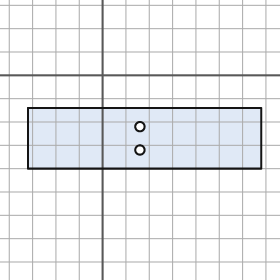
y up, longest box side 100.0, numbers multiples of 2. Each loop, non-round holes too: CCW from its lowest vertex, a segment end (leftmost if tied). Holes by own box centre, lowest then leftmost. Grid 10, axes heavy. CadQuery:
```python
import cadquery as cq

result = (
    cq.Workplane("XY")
    .moveTo(-32.0, -40.0)
    .lineTo(68.0, -40.0)
    .lineTo(68.0, -14.0)
    .lineTo(-32.0, -14.0)
    .close()
    .moveTo(16.0, -32.0)
    .circle(2.0)
    .moveTo(16.0, -22.0)
    .circle(2.0)
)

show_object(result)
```